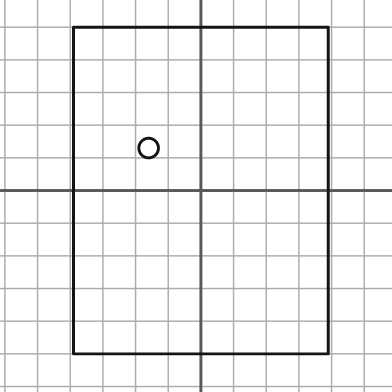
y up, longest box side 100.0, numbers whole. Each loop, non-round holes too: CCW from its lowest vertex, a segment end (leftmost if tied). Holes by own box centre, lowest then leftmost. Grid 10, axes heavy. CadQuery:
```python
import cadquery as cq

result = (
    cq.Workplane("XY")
    .moveTo(-39.0, -50.0)
    .lineTo(39.0, -50.0)
    .lineTo(39.0, 50.0)
    .lineTo(-39.0, 50.0)
    .close()
    .moveTo(-16.0, 13.0)
    .circle(3.0)
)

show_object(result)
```